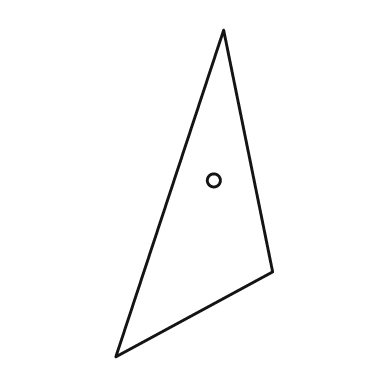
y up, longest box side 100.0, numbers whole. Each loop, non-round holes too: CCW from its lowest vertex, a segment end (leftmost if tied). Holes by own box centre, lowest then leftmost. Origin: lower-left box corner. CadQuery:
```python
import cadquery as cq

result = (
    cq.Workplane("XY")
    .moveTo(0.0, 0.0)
    .lineTo(48.0, 26.0)
    .lineTo(33.0, 100.0)
    .close()
    .moveTo(30.0, 54.0)
    .circle(2.0)
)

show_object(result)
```